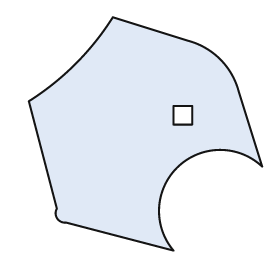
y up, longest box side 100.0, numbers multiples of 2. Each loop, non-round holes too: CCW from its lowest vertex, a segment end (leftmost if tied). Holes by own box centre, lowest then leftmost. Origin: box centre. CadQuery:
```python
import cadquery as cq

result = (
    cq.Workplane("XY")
    .moveTo(12.0, -50.0)
    .threePointArc((14.0, -14.0), (50.0, -14.0))
    .lineTo(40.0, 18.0)
    .threePointArc((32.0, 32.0), (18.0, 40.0))
    .lineTo(-14.0, 50.0)
    .threePointArc((-30.0, 30.0), (-50.0, 14.0))
    .lineTo(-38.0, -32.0)
    .threePointArc((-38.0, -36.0), (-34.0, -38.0))
    .close()
    .moveTo(12.0, 4.0)
    .lineTo(20.0, 4.0)
    .lineTo(20.0, 12.0)
    .lineTo(12.0, 12.0)
    .close()
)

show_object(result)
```